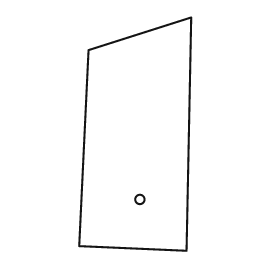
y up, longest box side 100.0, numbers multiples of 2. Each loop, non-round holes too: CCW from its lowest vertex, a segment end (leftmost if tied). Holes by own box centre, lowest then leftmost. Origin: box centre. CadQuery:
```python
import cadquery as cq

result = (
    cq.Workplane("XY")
    .moveTo(22.0, -50.0)
    .lineTo(24.0, 50.0)
    .lineTo(-20.0, 36.0)
    .lineTo(-24.0, -48.0)
    .close()
    .moveTo(2.0, -28.0)
    .circle(2.0)
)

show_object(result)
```